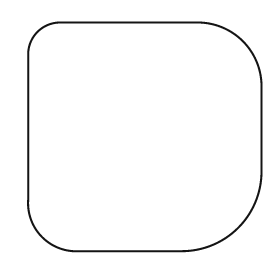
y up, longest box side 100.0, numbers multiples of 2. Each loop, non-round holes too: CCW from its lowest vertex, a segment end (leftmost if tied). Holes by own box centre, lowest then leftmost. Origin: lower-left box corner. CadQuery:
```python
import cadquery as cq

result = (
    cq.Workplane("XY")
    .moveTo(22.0, 0.0)
    .lineTo(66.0, 0.0)
    .threePointArc((90.0, 10.0), (100.0, 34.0))
    .lineTo(100.0, 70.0)
    .threePointArc((92.0, 90.0), (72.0, 98.0))
    .lineTo(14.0, 98.0)
    .threePointArc((4.0, 94.0), (0.0, 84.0))
    .lineTo(0.0, 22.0)
    .threePointArc((6.0, 6.0), (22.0, 0.0))
    .close()
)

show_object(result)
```